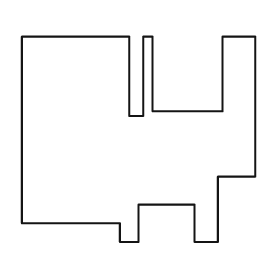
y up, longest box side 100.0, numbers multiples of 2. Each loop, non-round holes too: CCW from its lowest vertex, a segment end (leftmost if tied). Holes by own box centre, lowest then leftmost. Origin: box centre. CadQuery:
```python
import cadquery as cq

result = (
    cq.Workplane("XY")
    .moveTo(-8.0, -44.0)
    .lineTo(0.0, -44.0)
    .lineTo(0.0, -28.0)
    .lineTo(24.0, -28.0)
    .lineTo(24.0, -44.0)
    .lineTo(34.0, -44.0)
    .lineTo(34.0, -16.0)
    .lineTo(50.0, -16.0)
    .lineTo(50.0, 44.0)
    .lineTo(36.0, 44.0)
    .lineTo(36.0, 12.0)
    .lineTo(6.0, 12.0)
    .lineTo(6.0, 44.0)
    .lineTo(2.0, 44.0)
    .lineTo(2.0, 10.0)
    .lineTo(-4.0, 10.0)
    .lineTo(-4.0, 44.0)
    .lineTo(-50.0, 44.0)
    .lineTo(-50.0, -36.0)
    .lineTo(-8.0, -36.0)
    .close()
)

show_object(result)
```